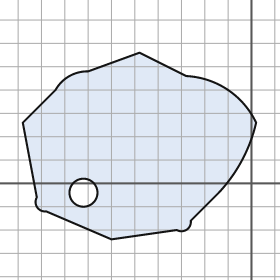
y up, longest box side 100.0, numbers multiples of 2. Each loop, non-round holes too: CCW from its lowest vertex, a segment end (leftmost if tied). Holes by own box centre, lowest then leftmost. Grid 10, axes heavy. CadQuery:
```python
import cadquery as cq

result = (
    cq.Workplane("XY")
    .moveTo(-60.0, -24.0)
    .lineTo(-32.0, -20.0)
    .threePointArc((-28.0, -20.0), (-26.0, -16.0))
    .lineTo(-14.0, -4.0)
    .threePointArc((-4.0, 10.0), (2.0, 26.0))
    .threePointArc((-10.0, 40.0), (-28.0, 46.0))
    .lineTo(-48.0, 56.0)
    .lineTo(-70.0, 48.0)
    .threePointArc((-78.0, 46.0), (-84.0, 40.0))
    .lineTo(-98.0, 26.0)
    .lineTo(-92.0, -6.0)
    .threePointArc((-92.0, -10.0), (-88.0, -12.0))
    .close()
    .moveTo(-72.0, -4.0)
    .circle(6.0)
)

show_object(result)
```